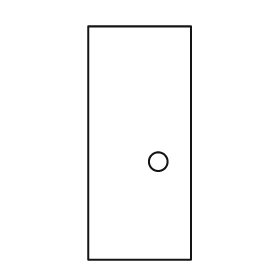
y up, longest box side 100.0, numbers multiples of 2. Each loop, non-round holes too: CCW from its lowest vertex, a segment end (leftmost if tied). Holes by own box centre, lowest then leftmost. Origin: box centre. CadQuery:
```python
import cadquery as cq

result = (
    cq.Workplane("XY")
    .moveTo(-22.0, -50.0)
    .lineTo(22.0, -50.0)
    .lineTo(22.0, 50.0)
    .lineTo(-22.0, 50.0)
    .close()
    .moveTo(8.0, -8.0)
    .circle(4.0)
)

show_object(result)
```